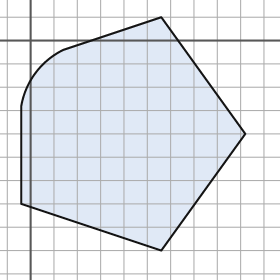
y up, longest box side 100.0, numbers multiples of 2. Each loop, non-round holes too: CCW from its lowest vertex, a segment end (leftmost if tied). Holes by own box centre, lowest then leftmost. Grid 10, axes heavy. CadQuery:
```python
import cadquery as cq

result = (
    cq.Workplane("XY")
    .moveTo(56.0, -90.0)
    .lineTo(92.0, -40.0)
    .lineTo(56.0, 10.0)
    .lineTo(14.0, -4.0)
    .threePointArc((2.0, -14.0), (-4.0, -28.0))
    .lineTo(-4.0, -70.0)
    .close()
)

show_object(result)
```